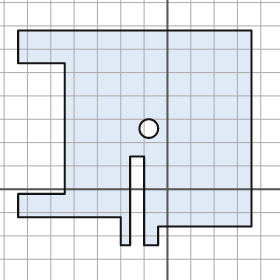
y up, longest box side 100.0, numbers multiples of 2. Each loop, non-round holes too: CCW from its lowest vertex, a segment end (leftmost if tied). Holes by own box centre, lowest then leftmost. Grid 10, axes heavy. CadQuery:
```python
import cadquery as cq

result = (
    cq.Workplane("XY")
    .moveTo(-20.0, -24.0)
    .lineTo(-16.0, -24.0)
    .lineTo(-16.0, 14.0)
    .lineTo(-10.0, 14.0)
    .lineTo(-10.0, -24.0)
    .lineTo(-4.0, -24.0)
    .lineTo(-4.0, -16.0)
    .lineTo(36.0, -16.0)
    .lineTo(36.0, 68.0)
    .lineTo(-64.0, 68.0)
    .lineTo(-64.0, 54.0)
    .lineTo(-44.0, 54.0)
    .lineTo(-44.0, -2.0)
    .lineTo(-64.0, -2.0)
    .lineTo(-64.0, -12.0)
    .lineTo(-20.0, -12.0)
    .close()
    .moveTo(-8.0, 26.0)
    .circle(4.0)
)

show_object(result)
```